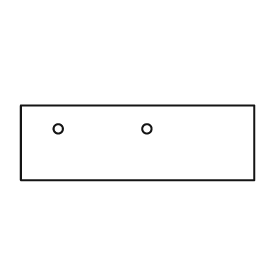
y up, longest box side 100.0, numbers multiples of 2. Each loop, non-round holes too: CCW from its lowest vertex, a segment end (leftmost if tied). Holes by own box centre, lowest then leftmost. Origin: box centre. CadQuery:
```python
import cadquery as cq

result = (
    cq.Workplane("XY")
    .moveTo(-50.0, -16.0)
    .lineTo(50.0, -16.0)
    .lineTo(50.0, 16.0)
    .lineTo(-50.0, 16.0)
    .close()
    .moveTo(-34.0, 6.0)
    .circle(2.0)
    .moveTo(4.0, 6.0)
    .circle(2.0)
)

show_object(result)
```